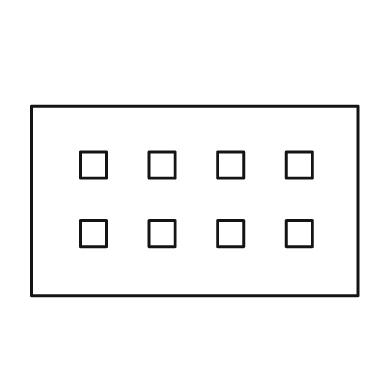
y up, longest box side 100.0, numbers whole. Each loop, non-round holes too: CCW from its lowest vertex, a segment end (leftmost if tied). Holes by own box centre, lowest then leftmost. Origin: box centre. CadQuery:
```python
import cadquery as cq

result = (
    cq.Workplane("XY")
    .moveTo(-50.0, -29.0)
    .lineTo(50.0, -29.0)
    .lineTo(50.0, 29.0)
    .lineTo(-50.0, 29.0)
    .close()
    .moveTo(-35.0, -14.0)
    .lineTo(-27.0, -14.0)
    .lineTo(-27.0, -6.0)
    .lineTo(-35.0, -6.0)
    .close()
    .moveTo(-14.0, -14.0)
    .lineTo(-6.0, -14.0)
    .lineTo(-6.0, -6.0)
    .lineTo(-14.0, -6.0)
    .close()
    .moveTo(7.0, -14.0)
    .lineTo(15.0, -14.0)
    .lineTo(15.0, -6.0)
    .lineTo(7.0, -6.0)
    .close()
    .moveTo(28.0, -14.0)
    .lineTo(36.0, -14.0)
    .lineTo(36.0, -6.0)
    .lineTo(28.0, -6.0)
    .close()
    .moveTo(-35.0, 7.0)
    .lineTo(-27.0, 7.0)
    .lineTo(-27.0, 15.0)
    .lineTo(-35.0, 15.0)
    .close()
    .moveTo(-14.0, 7.0)
    .lineTo(-6.0, 7.0)
    .lineTo(-6.0, 15.0)
    .lineTo(-14.0, 15.0)
    .close()
    .moveTo(7.0, 7.0)
    .lineTo(15.0, 7.0)
    .lineTo(15.0, 15.0)
    .lineTo(7.0, 15.0)
    .close()
    .moveTo(28.0, 7.0)
    .lineTo(36.0, 7.0)
    .lineTo(36.0, 15.0)
    .lineTo(28.0, 15.0)
    .close()
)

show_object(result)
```